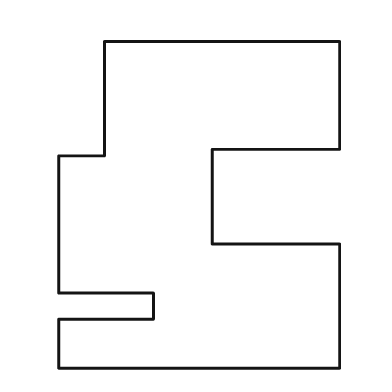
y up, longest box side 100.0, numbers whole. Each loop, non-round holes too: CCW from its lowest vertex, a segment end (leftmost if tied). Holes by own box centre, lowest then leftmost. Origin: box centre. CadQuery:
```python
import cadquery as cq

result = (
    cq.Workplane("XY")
    .moveTo(-43.0, -50.0)
    .lineTo(43.0, -50.0)
    .lineTo(43.0, -12.0)
    .lineTo(4.0, -12.0)
    .lineTo(4.0, 17.0)
    .lineTo(43.0, 17.0)
    .lineTo(43.0, 50.0)
    .lineTo(-29.0, 50.0)
    .lineTo(-29.0, 15.0)
    .lineTo(-43.0, 15.0)
    .lineTo(-43.0, -27.0)
    .lineTo(-14.0, -27.0)
    .lineTo(-14.0, -35.0)
    .lineTo(-43.0, -35.0)
    .close()
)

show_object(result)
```